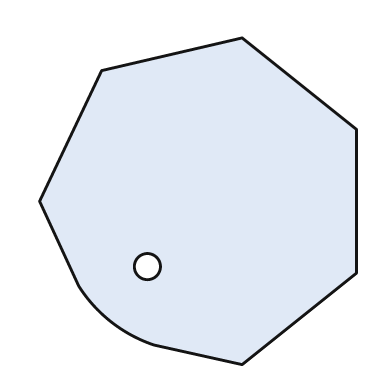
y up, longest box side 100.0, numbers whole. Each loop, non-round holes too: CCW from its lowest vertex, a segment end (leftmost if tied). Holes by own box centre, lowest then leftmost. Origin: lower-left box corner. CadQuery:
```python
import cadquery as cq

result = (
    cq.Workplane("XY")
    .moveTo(62.0, 0.0)
    .lineTo(97.0, 28.0)
    .lineTo(97.0, 72.0)
    .lineTo(62.0, 100.0)
    .lineTo(19.0, 90.0)
    .lineTo(0.0, 50.0)
    .lineTo(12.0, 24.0)
    .threePointArc((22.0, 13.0), (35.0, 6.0))
    .close()
    .moveTo(33.0, 30.0)
    .circle(4.0)
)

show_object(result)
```